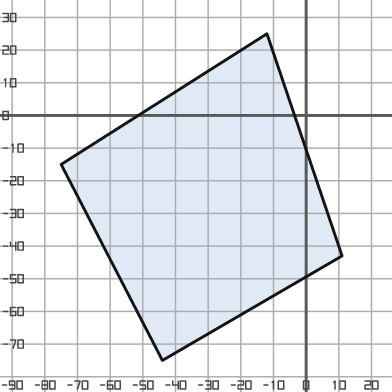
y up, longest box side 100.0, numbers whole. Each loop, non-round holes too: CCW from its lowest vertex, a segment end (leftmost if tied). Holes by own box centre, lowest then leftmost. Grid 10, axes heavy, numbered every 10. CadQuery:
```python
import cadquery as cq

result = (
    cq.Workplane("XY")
    .moveTo(-44.0, -75.0)
    .lineTo(11.0, -43.0)
    .lineTo(-12.0, 25.0)
    .lineTo(-75.0, -15.0)
    .close()
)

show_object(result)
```